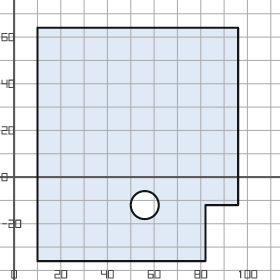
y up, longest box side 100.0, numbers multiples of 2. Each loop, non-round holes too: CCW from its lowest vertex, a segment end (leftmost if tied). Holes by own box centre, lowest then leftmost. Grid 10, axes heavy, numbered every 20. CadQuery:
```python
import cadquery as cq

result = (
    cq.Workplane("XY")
    .moveTo(10.0, -36.0)
    .lineTo(82.0, -36.0)
    .lineTo(82.0, -12.0)
    .lineTo(96.0, -12.0)
    .lineTo(96.0, 64.0)
    .lineTo(10.0, 64.0)
    .close()
    .moveTo(56.0, -12.0)
    .circle(6.0)
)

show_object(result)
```